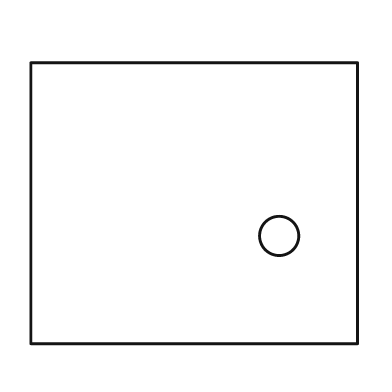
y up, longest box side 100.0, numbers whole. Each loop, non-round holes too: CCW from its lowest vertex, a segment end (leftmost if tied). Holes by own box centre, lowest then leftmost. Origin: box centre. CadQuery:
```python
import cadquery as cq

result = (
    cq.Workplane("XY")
    .moveTo(-50.0, -43.0)
    .lineTo(50.0, -43.0)
    .lineTo(50.0, 43.0)
    .lineTo(-50.0, 43.0)
    .close()
    .moveTo(26.0, -10.0)
    .circle(6.0)
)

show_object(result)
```